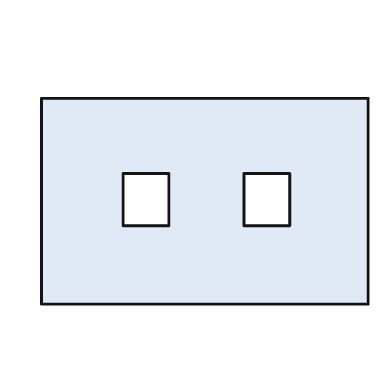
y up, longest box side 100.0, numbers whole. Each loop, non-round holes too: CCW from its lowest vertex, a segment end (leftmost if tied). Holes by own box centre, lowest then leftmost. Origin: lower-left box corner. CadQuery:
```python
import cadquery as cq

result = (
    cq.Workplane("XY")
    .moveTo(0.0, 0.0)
    .lineTo(100.0, 0.0)
    .lineTo(100.0, 63.0)
    .lineTo(0.0, 63.0)
    .close()
    .moveTo(25.0, 24.0)
    .lineTo(39.0, 24.0)
    .lineTo(39.0, 40.0)
    .lineTo(25.0, 40.0)
    .close()
    .moveTo(62.0, 24.0)
    .lineTo(76.0, 24.0)
    .lineTo(76.0, 40.0)
    .lineTo(62.0, 40.0)
    .close()
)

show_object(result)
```